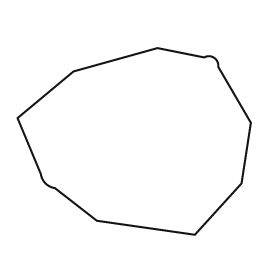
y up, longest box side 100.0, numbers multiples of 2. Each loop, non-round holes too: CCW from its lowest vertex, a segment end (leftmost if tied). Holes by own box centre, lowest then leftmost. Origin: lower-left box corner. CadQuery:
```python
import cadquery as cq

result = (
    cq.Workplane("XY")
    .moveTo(76.0, 0.0)
    .lineTo(96.0, 22.0)
    .lineTo(100.0, 48.0)
    .lineTo(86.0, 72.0)
    .threePointArc((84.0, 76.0), (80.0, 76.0))
    .lineTo(60.0, 80.0)
    .lineTo(24.0, 70.0)
    .lineTo(0.0, 50.0)
    .lineTo(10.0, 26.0)
    .threePointArc((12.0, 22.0), (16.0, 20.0))
    .lineTo(34.0, 6.0)
    .close()
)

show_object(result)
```